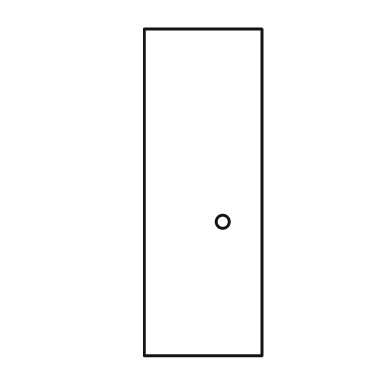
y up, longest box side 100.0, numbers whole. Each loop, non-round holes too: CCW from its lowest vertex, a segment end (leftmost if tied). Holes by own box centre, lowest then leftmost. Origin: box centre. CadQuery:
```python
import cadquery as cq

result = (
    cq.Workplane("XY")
    .moveTo(-18.0, -50.0)
    .lineTo(18.0, -50.0)
    .lineTo(18.0, 50.0)
    .lineTo(-18.0, 50.0)
    .close()
    .moveTo(6.0, -9.0)
    .circle(2.0)
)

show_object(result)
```